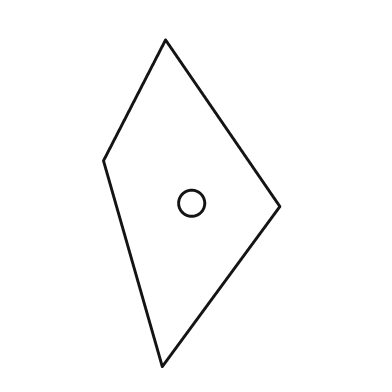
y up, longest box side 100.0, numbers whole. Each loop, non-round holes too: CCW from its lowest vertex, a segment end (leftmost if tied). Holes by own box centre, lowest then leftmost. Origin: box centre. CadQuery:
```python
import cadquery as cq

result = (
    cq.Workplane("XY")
    .moveTo(-9.0, -50.0)
    .lineTo(27.0, -1.0)
    .lineTo(-8.0, 50.0)
    .lineTo(-27.0, 13.0)
    .close()
    .moveTo(0.0, 0.0)
    .circle(4.0)
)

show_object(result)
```